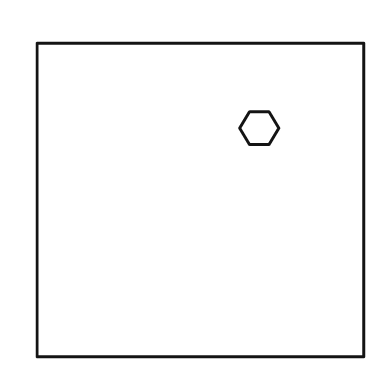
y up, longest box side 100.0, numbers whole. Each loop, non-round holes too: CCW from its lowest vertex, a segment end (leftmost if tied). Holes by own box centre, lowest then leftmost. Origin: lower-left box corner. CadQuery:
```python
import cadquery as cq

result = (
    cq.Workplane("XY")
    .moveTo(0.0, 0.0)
    .lineTo(100.0, 0.0)
    .lineTo(100.0, 96.0)
    .lineTo(0.0, 96.0)
    .close()
    .moveTo(65.0, 65.0)
    .lineTo(71.0, 65.0)
    .lineTo(74.0, 70.0)
    .lineTo(71.0, 75.0)
    .lineTo(65.0, 75.0)
    .lineTo(62.0, 70.0)
    .close()
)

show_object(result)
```